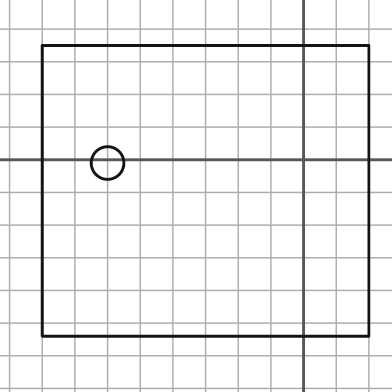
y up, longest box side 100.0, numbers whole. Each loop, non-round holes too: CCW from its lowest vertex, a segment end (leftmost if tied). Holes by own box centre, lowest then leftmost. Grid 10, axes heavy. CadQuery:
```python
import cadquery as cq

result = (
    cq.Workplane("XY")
    .moveTo(-80.0, -54.0)
    .lineTo(20.0, -54.0)
    .lineTo(20.0, 35.0)
    .lineTo(-80.0, 35.0)
    .close()
    .moveTo(-60.0, -1.0)
    .circle(5.0)
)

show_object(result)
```